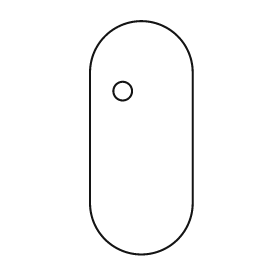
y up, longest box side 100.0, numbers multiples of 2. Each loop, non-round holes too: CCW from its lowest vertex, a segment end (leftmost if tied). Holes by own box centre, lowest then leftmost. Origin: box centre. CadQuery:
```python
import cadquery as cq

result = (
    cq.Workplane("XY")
    .moveTo(-22.0, -28.0)
    .threePointArc((0.0, -50.0), (22.0, -28.0))
    .lineTo(22.0, 28.0)
    .threePointArc((0.0, 50.0), (-22.0, 28.0))
    .close()
    .moveTo(-8.0, 20.0)
    .circle(4.0)
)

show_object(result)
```